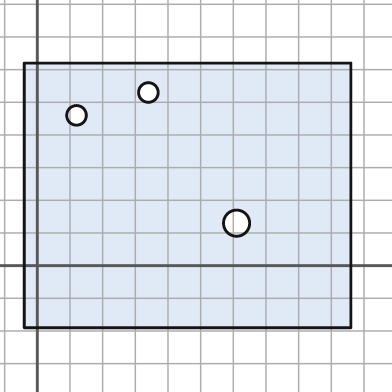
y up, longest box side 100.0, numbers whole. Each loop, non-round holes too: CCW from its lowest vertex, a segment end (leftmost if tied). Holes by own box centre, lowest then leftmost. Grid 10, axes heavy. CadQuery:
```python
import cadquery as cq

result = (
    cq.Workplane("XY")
    .moveTo(-4.0, -19.0)
    .lineTo(96.0, -19.0)
    .lineTo(96.0, 62.0)
    .lineTo(-4.0, 62.0)
    .close()
    .moveTo(61.0, 13.0)
    .circle(4.0)
    .moveTo(12.0, 46.0)
    .circle(3.0)
    .moveTo(34.0, 53.0)
    .circle(3.0)
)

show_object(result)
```